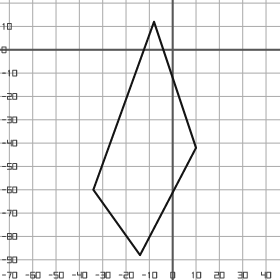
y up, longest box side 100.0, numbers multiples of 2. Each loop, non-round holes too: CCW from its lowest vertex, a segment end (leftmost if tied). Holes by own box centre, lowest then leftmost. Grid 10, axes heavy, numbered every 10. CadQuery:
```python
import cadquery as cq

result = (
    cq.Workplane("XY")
    .moveTo(-14.0, -88.0)
    .lineTo(10.0, -42.0)
    .lineTo(-8.0, 12.0)
    .lineTo(-34.0, -60.0)
    .close()
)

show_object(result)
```